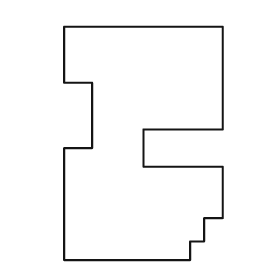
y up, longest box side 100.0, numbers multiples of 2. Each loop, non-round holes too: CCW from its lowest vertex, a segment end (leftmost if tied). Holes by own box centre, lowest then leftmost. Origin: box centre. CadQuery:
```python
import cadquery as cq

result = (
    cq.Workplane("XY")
    .moveTo(-34.0, -50.0)
    .lineTo(20.0, -50.0)
    .lineTo(20.0, -42.0)
    .lineTo(26.0, -42.0)
    .lineTo(26.0, -32.0)
    .lineTo(34.0, -32.0)
    .lineTo(34.0, -10.0)
    .lineTo(0.0, -10.0)
    .lineTo(0.0, 6.0)
    .lineTo(34.0, 6.0)
    .lineTo(34.0, 50.0)
    .lineTo(-34.0, 50.0)
    .lineTo(-34.0, 26.0)
    .lineTo(-22.0, 26.0)
    .lineTo(-22.0, -2.0)
    .lineTo(-34.0, -2.0)
    .close()
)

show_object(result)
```